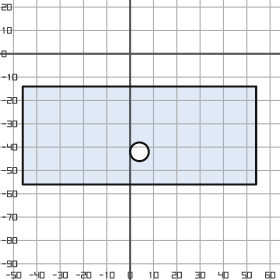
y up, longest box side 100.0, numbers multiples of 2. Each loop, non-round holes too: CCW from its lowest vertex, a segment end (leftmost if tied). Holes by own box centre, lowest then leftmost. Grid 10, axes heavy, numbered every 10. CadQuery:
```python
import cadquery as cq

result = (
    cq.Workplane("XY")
    .moveTo(-46.0, -56.0)
    .lineTo(54.0, -56.0)
    .lineTo(54.0, -14.0)
    .lineTo(-46.0, -14.0)
    .close()
    .moveTo(4.0, -42.0)
    .circle(4.0)
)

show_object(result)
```